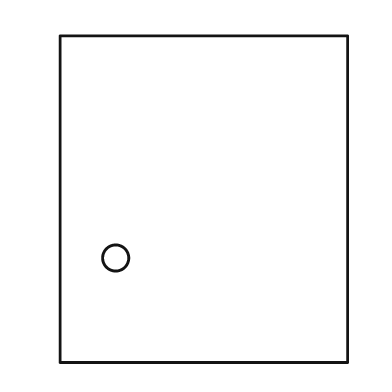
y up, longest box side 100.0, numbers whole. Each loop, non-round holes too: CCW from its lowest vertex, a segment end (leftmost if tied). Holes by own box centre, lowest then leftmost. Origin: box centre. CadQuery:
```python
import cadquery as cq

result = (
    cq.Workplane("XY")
    .moveTo(-44.0, -50.0)
    .lineTo(44.0, -50.0)
    .lineTo(44.0, 50.0)
    .lineTo(-44.0, 50.0)
    .close()
    .moveTo(-27.0, -18.0)
    .circle(4.0)
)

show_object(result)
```